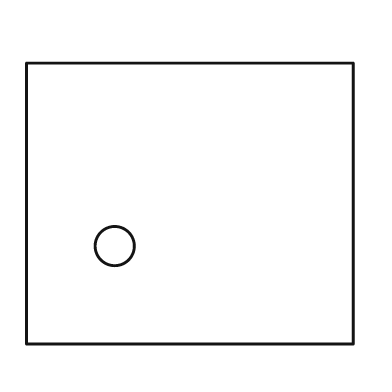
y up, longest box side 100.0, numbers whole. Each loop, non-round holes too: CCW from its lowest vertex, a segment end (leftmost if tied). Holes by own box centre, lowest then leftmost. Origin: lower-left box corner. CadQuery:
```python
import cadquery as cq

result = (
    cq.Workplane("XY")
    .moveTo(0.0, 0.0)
    .lineTo(100.0, 0.0)
    .lineTo(100.0, 86.0)
    .lineTo(0.0, 86.0)
    .close()
    .moveTo(27.0, 30.0)
    .circle(6.0)
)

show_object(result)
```